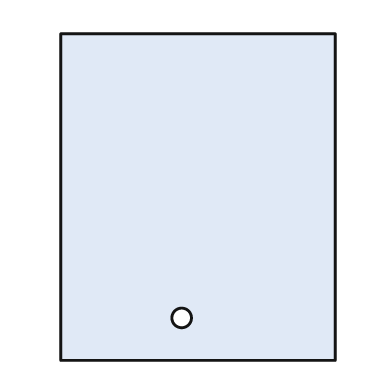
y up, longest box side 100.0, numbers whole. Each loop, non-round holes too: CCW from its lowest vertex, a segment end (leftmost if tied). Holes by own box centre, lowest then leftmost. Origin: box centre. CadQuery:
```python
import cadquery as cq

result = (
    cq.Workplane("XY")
    .moveTo(-42.0, -50.0)
    .lineTo(42.0, -50.0)
    .lineTo(42.0, 50.0)
    .lineTo(-42.0, 50.0)
    .close()
    .moveTo(-5.0, -37.0)
    .circle(3.0)
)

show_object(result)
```